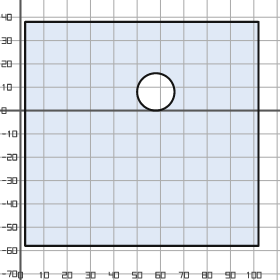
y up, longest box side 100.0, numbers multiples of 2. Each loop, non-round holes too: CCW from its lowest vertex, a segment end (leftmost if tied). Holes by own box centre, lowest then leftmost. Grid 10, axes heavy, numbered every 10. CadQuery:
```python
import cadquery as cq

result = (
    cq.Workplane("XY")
    .moveTo(2.0, -58.0)
    .lineTo(102.0, -58.0)
    .lineTo(102.0, 38.0)
    .lineTo(2.0, 38.0)
    .close()
    .moveTo(58.0, 8.0)
    .circle(8.0)
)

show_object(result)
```